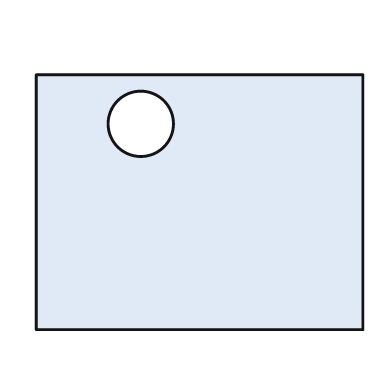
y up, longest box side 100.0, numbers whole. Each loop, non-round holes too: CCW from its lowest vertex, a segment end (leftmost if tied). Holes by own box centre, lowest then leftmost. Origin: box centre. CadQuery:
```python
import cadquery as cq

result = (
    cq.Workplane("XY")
    .moveTo(-50.0, -39.0)
    .lineTo(50.0, -39.0)
    .lineTo(50.0, 39.0)
    .lineTo(-50.0, 39.0)
    .close()
    .moveTo(-18.0, 24.0)
    .circle(10.0)
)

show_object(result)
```